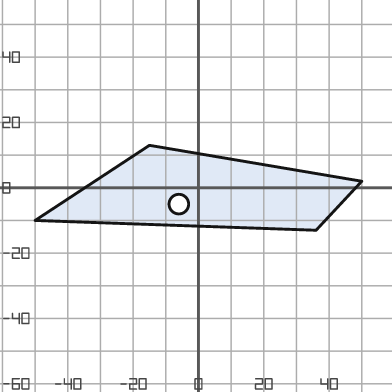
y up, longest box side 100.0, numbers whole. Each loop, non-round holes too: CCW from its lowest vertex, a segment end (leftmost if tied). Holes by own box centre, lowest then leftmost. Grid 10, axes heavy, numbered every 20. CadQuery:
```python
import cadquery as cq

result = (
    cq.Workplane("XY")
    .moveTo(36.0, -13.0)
    .lineTo(50.0, 2.0)
    .lineTo(-15.0, 13.0)
    .lineTo(-50.0, -10.0)
    .close()
    .moveTo(-6.0, -5.0)
    .circle(3.0)
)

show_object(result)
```